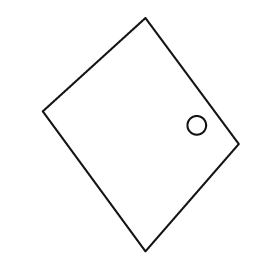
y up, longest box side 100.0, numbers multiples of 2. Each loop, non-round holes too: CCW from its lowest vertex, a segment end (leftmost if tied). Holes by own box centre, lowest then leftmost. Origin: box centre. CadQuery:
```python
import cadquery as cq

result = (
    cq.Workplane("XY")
    .moveTo(2.0, -50.0)
    .lineTo(42.0, -4.0)
    .lineTo(2.0, 50.0)
    .lineTo(-42.0, 10.0)
    .close()
    .moveTo(24.0, 4.0)
    .circle(4.0)
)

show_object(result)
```